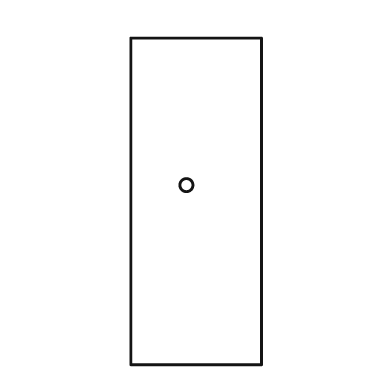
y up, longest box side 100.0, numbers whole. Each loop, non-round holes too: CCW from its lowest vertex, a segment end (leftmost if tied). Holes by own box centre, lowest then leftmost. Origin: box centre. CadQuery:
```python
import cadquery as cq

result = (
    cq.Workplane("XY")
    .moveTo(-20.0, -50.0)
    .lineTo(20.0, -50.0)
    .lineTo(20.0, 50.0)
    .lineTo(-20.0, 50.0)
    .close()
    .moveTo(-3.0, 5.0)
    .circle(2.0)
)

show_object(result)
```